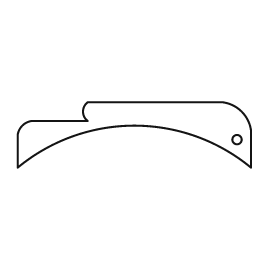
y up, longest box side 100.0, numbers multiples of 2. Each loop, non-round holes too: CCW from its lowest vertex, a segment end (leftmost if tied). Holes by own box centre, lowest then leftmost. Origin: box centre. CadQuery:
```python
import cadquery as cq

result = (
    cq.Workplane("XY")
    .moveTo(-50.0, -14.0)
    .threePointArc((0.0, 4.0), (50.0, -14.0))
    .lineTo(50.0, 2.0)
    .threePointArc((46.0, 10.0), (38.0, 14.0))
    .lineTo(-20.0, 14.0)
    .threePointArc((-22.0, 10.0), (-20.0, 6.0))
    .lineTo(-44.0, 6.0)
    .threePointArc((-48.0, 4.0), (-50.0, 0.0))
    .close()
    .moveTo(44.0, -2.0)
    .circle(2.0)
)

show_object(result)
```